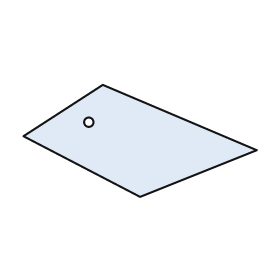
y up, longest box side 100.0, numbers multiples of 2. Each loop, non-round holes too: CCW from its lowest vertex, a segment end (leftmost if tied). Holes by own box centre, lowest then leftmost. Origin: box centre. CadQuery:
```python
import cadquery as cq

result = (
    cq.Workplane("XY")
    .moveTo(0.0, -24.0)
    .lineTo(50.0, -4.0)
    .lineTo(-16.0, 24.0)
    .lineTo(-50.0, 2.0)
    .close()
    .moveTo(-22.0, 8.0)
    .circle(2.0)
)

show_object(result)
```